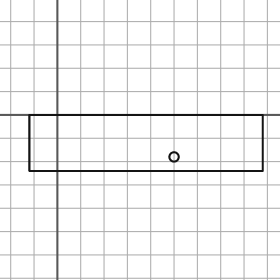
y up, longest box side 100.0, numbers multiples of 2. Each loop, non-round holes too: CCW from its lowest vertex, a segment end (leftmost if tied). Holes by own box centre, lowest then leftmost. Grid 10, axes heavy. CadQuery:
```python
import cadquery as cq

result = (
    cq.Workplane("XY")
    .moveTo(-12.0, -24.0)
    .lineTo(88.0, -24.0)
    .lineTo(88.0, 0.0)
    .lineTo(-12.0, 0.0)
    .close()
    .moveTo(50.0, -18.0)
    .circle(2.0)
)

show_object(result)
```